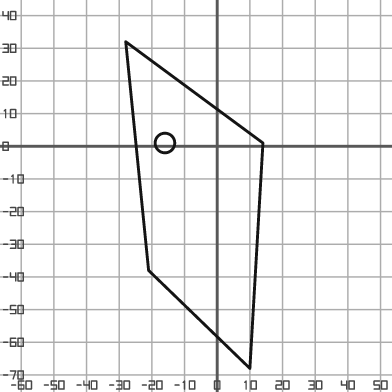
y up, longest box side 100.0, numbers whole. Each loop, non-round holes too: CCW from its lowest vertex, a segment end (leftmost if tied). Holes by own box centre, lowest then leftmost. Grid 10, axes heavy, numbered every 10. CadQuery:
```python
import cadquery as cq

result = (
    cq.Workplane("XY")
    .moveTo(10.0, -68.0)
    .lineTo(14.0, 1.0)
    .lineTo(-28.0, 32.0)
    .lineTo(-21.0, -38.0)
    .close()
    .moveTo(-16.0, 1.0)
    .circle(3.0)
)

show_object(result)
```